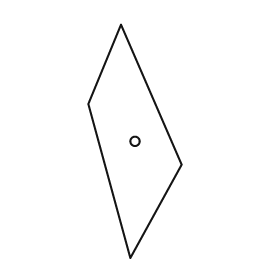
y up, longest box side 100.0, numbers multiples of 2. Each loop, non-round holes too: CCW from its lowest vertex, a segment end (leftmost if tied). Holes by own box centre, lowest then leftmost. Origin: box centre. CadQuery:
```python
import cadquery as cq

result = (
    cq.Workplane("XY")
    .moveTo(-2.0, -50.0)
    .lineTo(20.0, -10.0)
    .lineTo(-6.0, 50.0)
    .lineTo(-20.0, 16.0)
    .close()
    .moveTo(0.0, 0.0)
    .circle(2.0)
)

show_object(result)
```